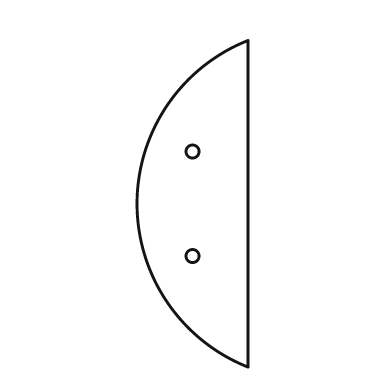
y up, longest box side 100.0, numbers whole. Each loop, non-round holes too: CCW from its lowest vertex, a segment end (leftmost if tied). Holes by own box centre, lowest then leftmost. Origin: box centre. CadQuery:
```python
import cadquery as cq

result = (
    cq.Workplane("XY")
    .moveTo(17.0, -50.0)
    .lineTo(17.0, 50.0)
    .threePointArc((-17.0, 0.0), (17.0, -50.0))
    .close()
    .moveTo(0.0, -16.0)
    .circle(2.0)
    .moveTo(0.0, 16.0)
    .circle(2.0)
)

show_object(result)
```